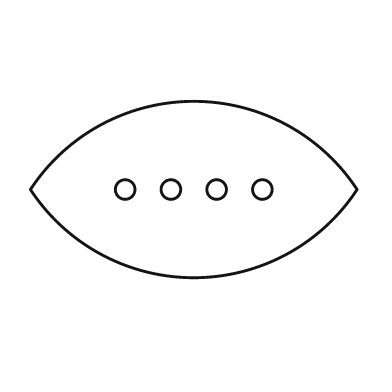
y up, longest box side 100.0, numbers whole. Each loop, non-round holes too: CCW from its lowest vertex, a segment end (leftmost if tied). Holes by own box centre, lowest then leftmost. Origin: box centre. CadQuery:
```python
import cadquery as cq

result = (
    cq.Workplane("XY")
    .moveTo(-50.0, 0.0)
    .threePointArc((0.0, -27.0), (50.0, 0.0))
    .threePointArc((0.0, 27.0), (-50.0, 0.0))
    .close()
    .moveTo(-21.0, 0.0)
    .circle(3.0)
    .moveTo(-7.0, 0.0)
    .circle(3.0)
    .moveTo(7.0, 0.0)
    .circle(3.0)
    .moveTo(21.0, 0.0)
    .circle(3.0)
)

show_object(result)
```